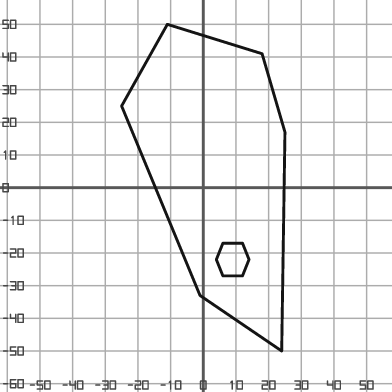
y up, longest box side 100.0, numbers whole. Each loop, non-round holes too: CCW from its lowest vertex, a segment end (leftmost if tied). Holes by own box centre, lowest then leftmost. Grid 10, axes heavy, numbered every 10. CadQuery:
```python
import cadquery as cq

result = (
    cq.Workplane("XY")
    .moveTo(24.0, -50.0)
    .lineTo(25.0, 17.0)
    .lineTo(18.0, 41.0)
    .lineTo(-11.0, 50.0)
    .lineTo(-25.0, 25.0)
    .lineTo(-1.0, -33.0)
    .close()
    .moveTo(6.0, -27.0)
    .lineTo(12.0, -27.0)
    .lineTo(14.0, -22.0)
    .lineTo(12.0, -17.0)
    .lineTo(6.0, -17.0)
    .lineTo(4.0, -22.0)
    .close()
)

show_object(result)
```